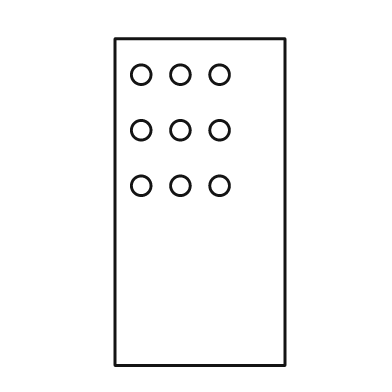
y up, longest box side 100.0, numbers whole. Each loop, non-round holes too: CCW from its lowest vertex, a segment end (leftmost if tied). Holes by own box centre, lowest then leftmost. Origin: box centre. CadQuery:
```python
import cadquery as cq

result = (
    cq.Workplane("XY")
    .moveTo(-26.0, -50.0)
    .lineTo(26.0, -50.0)
    .lineTo(26.0, 50.0)
    .lineTo(-26.0, 50.0)
    .close()
    .moveTo(-18.0, 5.0)
    .circle(3.0)
    .moveTo(-6.0, 5.0)
    .circle(3.0)
    .moveTo(6.0, 5.0)
    .circle(3.0)
    .moveTo(-18.0, 22.0)
    .circle(3.0)
    .moveTo(-6.0, 22.0)
    .circle(3.0)
    .moveTo(6.0, 22.0)
    .circle(3.0)
    .moveTo(-18.0, 39.0)
    .circle(3.0)
    .moveTo(-6.0, 39.0)
    .circle(3.0)
    .moveTo(6.0, 39.0)
    .circle(3.0)
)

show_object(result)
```